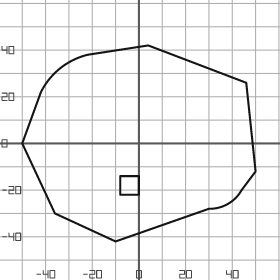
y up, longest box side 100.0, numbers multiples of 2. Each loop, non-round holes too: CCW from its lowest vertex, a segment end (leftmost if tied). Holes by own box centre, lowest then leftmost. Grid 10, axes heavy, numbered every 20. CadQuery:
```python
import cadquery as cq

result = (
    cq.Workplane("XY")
    .moveTo(-10.0, -42.0)
    .lineTo(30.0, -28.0)
    .threePointArc((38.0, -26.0), (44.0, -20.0))
    .lineTo(50.0, -12.0)
    .lineTo(46.0, 26.0)
    .lineTo(4.0, 42.0)
    .lineTo(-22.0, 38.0)
    .threePointArc((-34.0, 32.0), (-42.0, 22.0))
    .lineTo(-50.0, 0.0)
    .lineTo(-36.0, -30.0)
    .close()
    .moveTo(-8.0, -22.0)
    .lineTo(0.0, -22.0)
    .lineTo(0.0, -14.0)
    .lineTo(-8.0, -14.0)
    .close()
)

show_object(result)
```